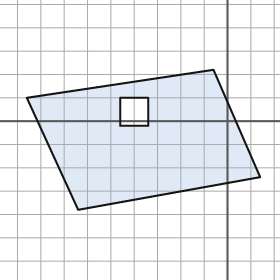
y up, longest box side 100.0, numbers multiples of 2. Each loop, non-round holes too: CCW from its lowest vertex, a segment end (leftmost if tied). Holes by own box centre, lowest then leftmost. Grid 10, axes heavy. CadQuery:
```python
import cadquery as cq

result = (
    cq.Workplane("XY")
    .moveTo(-64.0, -38.0)
    .lineTo(14.0, -24.0)
    .lineTo(-6.0, 22.0)
    .lineTo(-86.0, 10.0)
    .close()
    .moveTo(-46.0, -2.0)
    .lineTo(-34.0, -2.0)
    .lineTo(-34.0, 10.0)
    .lineTo(-46.0, 10.0)
    .close()
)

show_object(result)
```